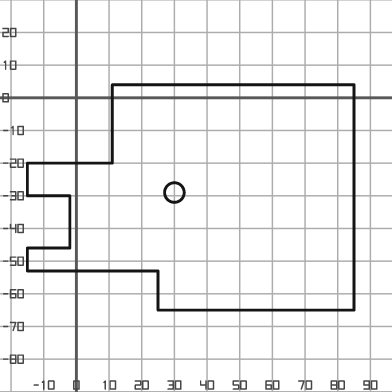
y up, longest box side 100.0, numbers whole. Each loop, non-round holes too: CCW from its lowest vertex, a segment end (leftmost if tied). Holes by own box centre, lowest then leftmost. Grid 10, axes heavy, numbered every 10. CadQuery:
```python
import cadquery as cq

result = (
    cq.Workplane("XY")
    .moveTo(25.0, -65.0)
    .lineTo(85.0, -65.0)
    .lineTo(85.0, 4.0)
    .lineTo(11.0, 4.0)
    .lineTo(11.0, -20.0)
    .lineTo(-15.0, -20.0)
    .lineTo(-15.0, -30.0)
    .lineTo(-2.0, -30.0)
    .lineTo(-2.0, -46.0)
    .lineTo(-15.0, -46.0)
    .lineTo(-15.0, -53.0)
    .lineTo(25.0, -53.0)
    .close()
    .moveTo(30.0, -29.0)
    .circle(3.0)
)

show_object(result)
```